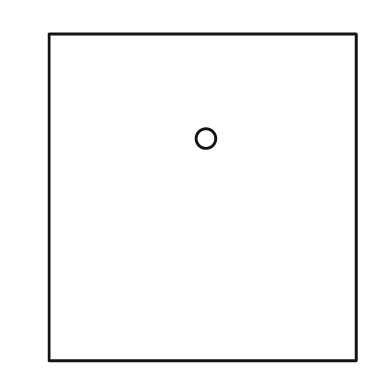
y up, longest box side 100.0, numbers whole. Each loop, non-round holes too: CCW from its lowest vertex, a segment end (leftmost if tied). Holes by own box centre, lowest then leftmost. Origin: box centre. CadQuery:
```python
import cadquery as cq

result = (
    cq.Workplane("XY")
    .moveTo(-47.0, -50.0)
    .lineTo(47.0, -50.0)
    .lineTo(47.0, 50.0)
    .lineTo(-47.0, 50.0)
    .close()
    .moveTo(1.0, 18.0)
    .circle(3.0)
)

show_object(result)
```